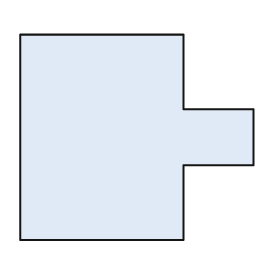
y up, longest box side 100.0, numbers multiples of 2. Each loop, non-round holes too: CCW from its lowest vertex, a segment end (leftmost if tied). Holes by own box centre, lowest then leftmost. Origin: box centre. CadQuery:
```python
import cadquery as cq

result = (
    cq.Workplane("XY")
    .moveTo(-50.0, -44.0)
    .lineTo(20.0, -44.0)
    .lineTo(20.0, -12.0)
    .lineTo(50.0, -12.0)
    .lineTo(50.0, 12.0)
    .lineTo(20.0, 12.0)
    .lineTo(20.0, 44.0)
    .lineTo(-50.0, 44.0)
    .close()
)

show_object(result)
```